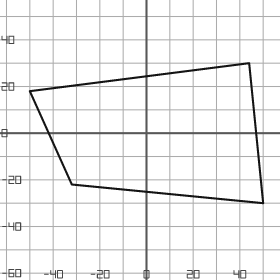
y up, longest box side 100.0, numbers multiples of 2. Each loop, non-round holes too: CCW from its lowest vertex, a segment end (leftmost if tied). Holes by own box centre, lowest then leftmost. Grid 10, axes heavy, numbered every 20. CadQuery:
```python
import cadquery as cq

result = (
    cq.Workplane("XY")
    .moveTo(50.0, -30.0)
    .lineTo(44.0, 30.0)
    .lineTo(-50.0, 18.0)
    .lineTo(-32.0, -22.0)
    .close()
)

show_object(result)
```